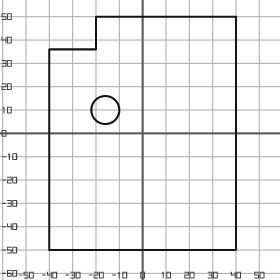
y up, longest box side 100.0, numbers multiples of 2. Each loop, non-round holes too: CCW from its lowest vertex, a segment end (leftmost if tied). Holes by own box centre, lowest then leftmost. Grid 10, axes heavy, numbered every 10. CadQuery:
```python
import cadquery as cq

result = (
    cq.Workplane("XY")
    .moveTo(-40.0, -50.0)
    .lineTo(40.0, -50.0)
    .lineTo(40.0, 50.0)
    .lineTo(-20.0, 50.0)
    .lineTo(-20.0, 36.0)
    .lineTo(-40.0, 36.0)
    .close()
    .moveTo(-16.0, 10.0)
    .circle(6.0)
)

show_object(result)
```